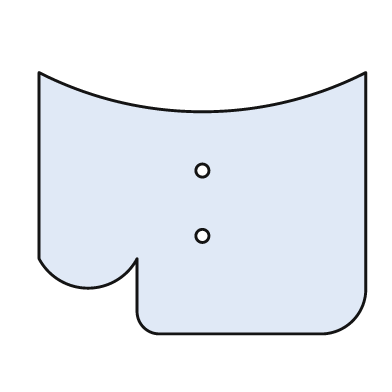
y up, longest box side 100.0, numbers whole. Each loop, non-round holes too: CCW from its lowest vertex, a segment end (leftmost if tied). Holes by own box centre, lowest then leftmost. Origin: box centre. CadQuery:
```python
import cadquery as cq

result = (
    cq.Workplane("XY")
    .moveTo(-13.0, -40.0)
    .lineTo(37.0, -40.0)
    .threePointArc((46.0, -36.0), (50.0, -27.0))
    .lineTo(50.0, 40.0)
    .threePointArc((0.0, 28.0), (-50.0, 40.0))
    .lineTo(-50.0, -17.0)
    .threePointArc((-35.0, -26.0), (-20.0, -17.0))
    .lineTo(-20.0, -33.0)
    .threePointArc((-18.0, -38.0), (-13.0, -40.0))
    .close()
    .moveTo(0.0, -10.0)
    .circle(2.0)
    .moveTo(0.0, 10.0)
    .circle(2.0)
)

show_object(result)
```